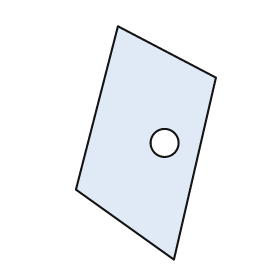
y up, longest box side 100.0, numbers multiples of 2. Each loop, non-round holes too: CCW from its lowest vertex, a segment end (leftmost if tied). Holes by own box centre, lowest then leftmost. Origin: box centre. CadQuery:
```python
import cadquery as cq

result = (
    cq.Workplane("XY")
    .moveTo(12.0, -50.0)
    .lineTo(30.0, 28.0)
    .lineTo(-12.0, 50.0)
    .lineTo(-30.0, -20.0)
    .close()
    .moveTo(8.0, 0.0)
    .circle(6.0)
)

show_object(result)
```